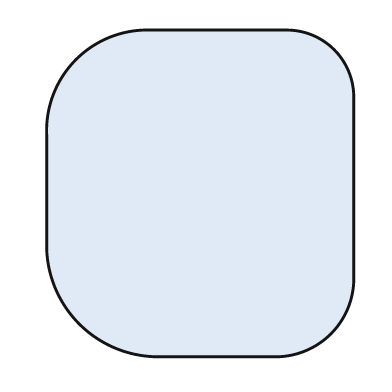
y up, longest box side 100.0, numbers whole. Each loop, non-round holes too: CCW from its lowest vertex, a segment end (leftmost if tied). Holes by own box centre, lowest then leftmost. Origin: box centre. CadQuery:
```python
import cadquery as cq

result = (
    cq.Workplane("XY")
    .moveTo(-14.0, -50.0)
    .lineTo(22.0, -50.0)
    .threePointArc((40.0, -43.0), (47.0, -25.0))
    .lineTo(47.0, 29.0)
    .threePointArc((41.0, 44.0), (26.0, 50.0))
    .lineTo(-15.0, 50.0)
    .threePointArc((-38.0, 41.0), (-47.0, 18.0))
    .lineTo(-47.0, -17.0)
    .threePointArc((-37.0, -40.0), (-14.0, -50.0))
    .close()
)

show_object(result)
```